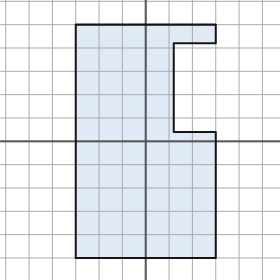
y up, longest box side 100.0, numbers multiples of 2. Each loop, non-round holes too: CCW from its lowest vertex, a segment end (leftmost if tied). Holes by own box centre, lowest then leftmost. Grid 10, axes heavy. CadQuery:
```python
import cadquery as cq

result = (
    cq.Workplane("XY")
    .moveTo(-30.0, -50.0)
    .lineTo(30.0, -50.0)
    .lineTo(30.0, 4.0)
    .lineTo(12.0, 4.0)
    .lineTo(12.0, 42.0)
    .lineTo(30.0, 42.0)
    .lineTo(30.0, 50.0)
    .lineTo(-30.0, 50.0)
    .close()
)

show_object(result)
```